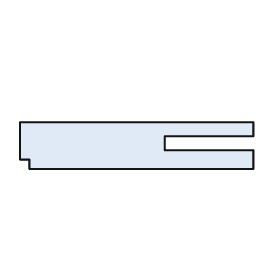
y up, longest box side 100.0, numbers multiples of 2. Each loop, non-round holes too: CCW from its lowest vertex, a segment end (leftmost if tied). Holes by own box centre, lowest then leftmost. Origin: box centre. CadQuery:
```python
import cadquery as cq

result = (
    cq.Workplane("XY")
    .moveTo(-46.0, -10.0)
    .lineTo(50.0, -10.0)
    .lineTo(50.0, -2.0)
    .lineTo(12.0, -2.0)
    .lineTo(12.0, 4.0)
    .lineTo(50.0, 4.0)
    .lineTo(50.0, 10.0)
    .lineTo(-50.0, 10.0)
    .lineTo(-50.0, -6.0)
    .lineTo(-46.0, -6.0)
    .close()
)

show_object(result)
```